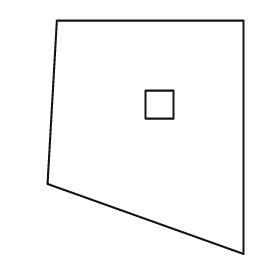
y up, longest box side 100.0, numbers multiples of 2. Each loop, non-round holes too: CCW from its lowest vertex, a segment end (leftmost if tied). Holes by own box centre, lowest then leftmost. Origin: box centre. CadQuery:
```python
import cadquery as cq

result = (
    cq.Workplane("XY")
    .moveTo(42.0, -50.0)
    .lineTo(42.0, 50.0)
    .lineTo(-38.0, 50.0)
    .lineTo(-42.0, -20.0)
    .close()
    .moveTo(0.0, 8.0)
    .lineTo(12.0, 8.0)
    .lineTo(12.0, 20.0)
    .lineTo(0.0, 20.0)
    .close()
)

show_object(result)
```